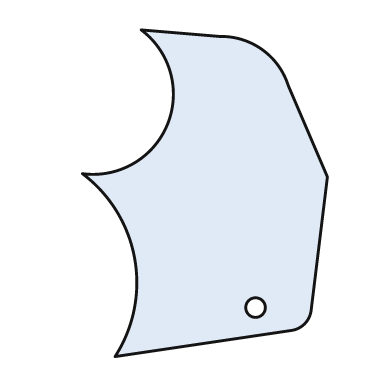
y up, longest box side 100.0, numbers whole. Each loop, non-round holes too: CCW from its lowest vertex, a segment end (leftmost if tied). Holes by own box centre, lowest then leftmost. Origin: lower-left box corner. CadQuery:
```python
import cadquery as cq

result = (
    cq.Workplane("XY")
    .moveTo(10.0, 0.0)
    .lineTo(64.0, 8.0)
    .threePointArc((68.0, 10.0), (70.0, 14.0))
    .lineTo(75.0, 55.0)
    .lineTo(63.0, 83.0)
    .threePointArc((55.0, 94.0), (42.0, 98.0))
    .lineTo(18.0, 100.0)
    .threePointArc((26.0, 71.0), (0.0, 56.0))
    .threePointArc((16.0, 30.0), (10.0, 0.0))
    .close()
    .moveTo(53.0, 15.0)
    .circle(3.0)
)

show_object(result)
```